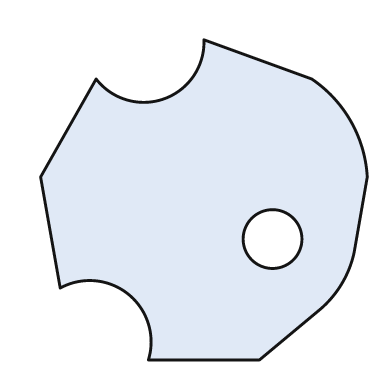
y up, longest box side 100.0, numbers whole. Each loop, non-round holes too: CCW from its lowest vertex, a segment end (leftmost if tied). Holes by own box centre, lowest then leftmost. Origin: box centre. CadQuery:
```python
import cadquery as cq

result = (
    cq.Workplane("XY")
    .moveTo(-17.0, -49.0)
    .lineTo(17.0, -49.0)
    .lineTo(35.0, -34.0)
    .threePointArc((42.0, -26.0), (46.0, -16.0))
    .lineTo(50.0, 7.0)
    .threePointArc((45.0, 24.0), (33.0, 37.0))
    .lineTo(0.0, 49.0)
    .threePointArc((-12.0, 31.0), (-33.0, 37.0))
    .lineTo(-50.0, 7.0)
    .lineTo(-44.0, -27.0)
    .threePointArc((-23.0, -29.0), (-17.0, -49.0))
    .close()
    .moveTo(21.0, -12.0)
    .circle(9.0)
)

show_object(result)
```